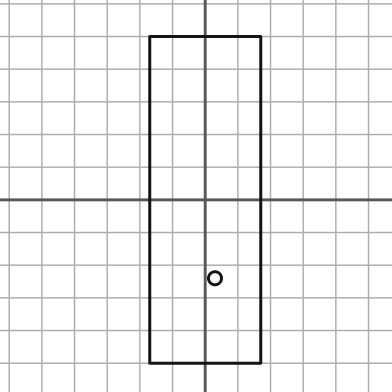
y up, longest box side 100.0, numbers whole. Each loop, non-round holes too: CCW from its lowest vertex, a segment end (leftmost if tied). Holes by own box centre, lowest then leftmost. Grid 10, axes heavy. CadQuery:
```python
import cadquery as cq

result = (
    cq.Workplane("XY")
    .moveTo(-17.0, -50.0)
    .lineTo(17.0, -50.0)
    .lineTo(17.0, 50.0)
    .lineTo(-17.0, 50.0)
    .close()
    .moveTo(3.0, -24.0)
    .circle(2.0)
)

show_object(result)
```